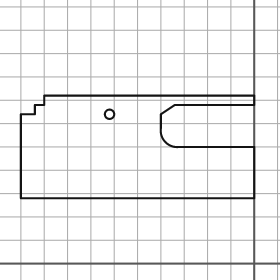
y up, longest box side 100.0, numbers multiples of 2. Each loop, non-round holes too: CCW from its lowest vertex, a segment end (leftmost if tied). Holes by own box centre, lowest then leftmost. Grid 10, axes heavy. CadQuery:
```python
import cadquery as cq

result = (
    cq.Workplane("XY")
    .moveTo(-100.0, 28.0)
    .lineTo(0.0, 28.0)
    .lineTo(0.0, 50.0)
    .lineTo(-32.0, 50.0)
    .threePointArc((-38.0, 52.0), (-40.0, 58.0))
    .lineTo(-40.0, 64.0)
    .lineTo(-34.0, 68.0)
    .lineTo(0.0, 68.0)
    .lineTo(0.0, 72.0)
    .lineTo(-90.0, 72.0)
    .lineTo(-90.0, 68.0)
    .lineTo(-94.0, 68.0)
    .lineTo(-94.0, 64.0)
    .lineTo(-100.0, 64.0)
    .close()
    .moveTo(-62.0, 64.0)
    .circle(2.0)
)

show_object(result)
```